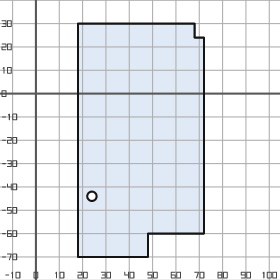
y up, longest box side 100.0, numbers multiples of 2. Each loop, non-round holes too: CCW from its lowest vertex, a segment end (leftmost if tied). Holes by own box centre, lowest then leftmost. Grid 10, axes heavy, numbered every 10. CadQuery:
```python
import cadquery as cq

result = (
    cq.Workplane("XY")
    .moveTo(18.0, -70.0)
    .lineTo(48.0, -70.0)
    .lineTo(48.0, -60.0)
    .lineTo(72.0, -60.0)
    .lineTo(72.0, 24.0)
    .lineTo(68.0, 24.0)
    .lineTo(68.0, 30.0)
    .lineTo(18.0, 30.0)
    .close()
    .moveTo(24.0, -44.0)
    .circle(2.0)
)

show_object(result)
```